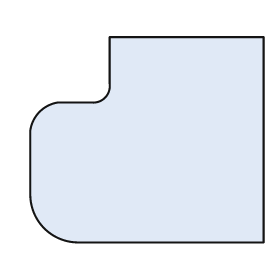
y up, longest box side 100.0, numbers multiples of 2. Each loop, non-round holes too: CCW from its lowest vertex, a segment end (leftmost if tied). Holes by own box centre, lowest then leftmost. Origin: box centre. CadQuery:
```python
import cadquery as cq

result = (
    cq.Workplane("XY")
    .moveTo(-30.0, -44.0)
    .lineTo(50.0, -44.0)
    .lineTo(50.0, 44.0)
    .lineTo(-16.0, 44.0)
    .lineTo(-16.0, 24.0)
    .threePointArc((-18.0, 18.0), (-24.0, 16.0))
    .lineTo(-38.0, 16.0)
    .threePointArc((-46.0, 12.0), (-50.0, 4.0))
    .lineTo(-50.0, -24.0)
    .threePointArc((-44.0, -38.0), (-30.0, -44.0))
    .close()
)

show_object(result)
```